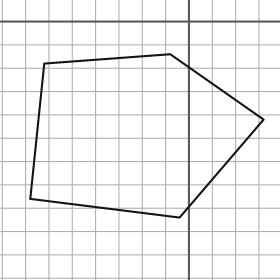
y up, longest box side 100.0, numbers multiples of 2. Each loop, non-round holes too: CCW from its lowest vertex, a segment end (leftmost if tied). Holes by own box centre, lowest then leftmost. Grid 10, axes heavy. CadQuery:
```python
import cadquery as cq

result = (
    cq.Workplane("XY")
    .moveTo(-4.0, -84.0)
    .lineTo(32.0, -42.0)
    .lineTo(-8.0, -14.0)
    .lineTo(-62.0, -18.0)
    .lineTo(-68.0, -76.0)
    .close()
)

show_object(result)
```